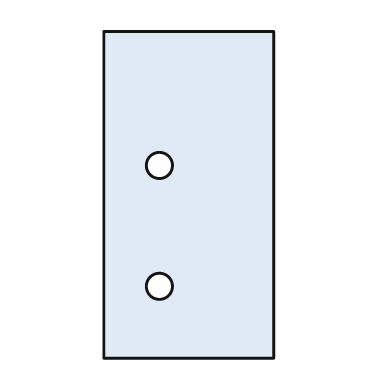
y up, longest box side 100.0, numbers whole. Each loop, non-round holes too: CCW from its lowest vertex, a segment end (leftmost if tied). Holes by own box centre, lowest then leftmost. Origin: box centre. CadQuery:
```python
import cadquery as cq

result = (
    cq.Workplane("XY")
    .moveTo(-26.0, -50.0)
    .lineTo(26.0, -50.0)
    .lineTo(26.0, 50.0)
    .lineTo(-26.0, 50.0)
    .close()
    .moveTo(-9.0, -28.0)
    .circle(4.0)
    .moveTo(-9.0, 9.0)
    .circle(4.0)
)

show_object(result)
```